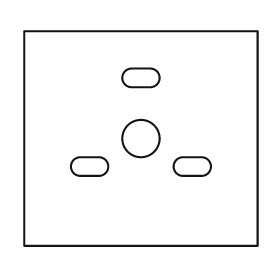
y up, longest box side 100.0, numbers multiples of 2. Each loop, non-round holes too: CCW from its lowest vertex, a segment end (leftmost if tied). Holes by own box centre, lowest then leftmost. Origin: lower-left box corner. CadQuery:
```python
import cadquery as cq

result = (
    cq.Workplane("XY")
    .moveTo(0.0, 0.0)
    .lineTo(100.0, 0.0)
    .lineTo(100.0, 92.0)
    .lineTo(0.0, 92.0)
    .close()
    .moveTo(24.0, 30.0)
    .lineTo(32.0, 30.0)
    .threePointArc((36.0, 34.0), (32.0, 38.0))
    .lineTo(24.0, 38.0)
    .threePointArc((20.0, 34.0), (24.0, 30.0))
    .close()
    .moveTo(68.0, 30.0)
    .lineTo(76.0, 30.0)
    .threePointArc((80.0, 34.0), (76.0, 38.0))
    .lineTo(68.0, 38.0)
    .threePointArc((64.0, 34.0), (68.0, 30.0))
    .close()
    .moveTo(50.0, 46.0)
    .circle(8.0)
    .moveTo(46.0, 68.0)
    .lineTo(54.0, 68.0)
    .threePointArc((58.0, 72.0), (54.0, 76.0))
    .lineTo(46.0, 76.0)
    .threePointArc((42.0, 72.0), (46.0, 68.0))
    .close()
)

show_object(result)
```